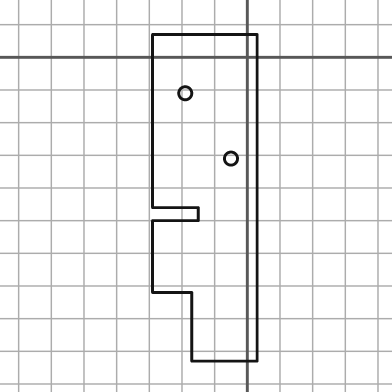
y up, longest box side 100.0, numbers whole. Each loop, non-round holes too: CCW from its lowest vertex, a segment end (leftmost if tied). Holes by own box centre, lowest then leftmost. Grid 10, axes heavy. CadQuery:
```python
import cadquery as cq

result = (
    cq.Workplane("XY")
    .moveTo(-17.0, -93.0)
    .lineTo(3.0, -93.0)
    .lineTo(3.0, 7.0)
    .lineTo(-29.0, 7.0)
    .lineTo(-29.0, -46.0)
    .lineTo(-15.0, -46.0)
    .lineTo(-15.0, -50.0)
    .lineTo(-29.0, -50.0)
    .lineTo(-29.0, -72.0)
    .lineTo(-17.0, -72.0)
    .close()
    .moveTo(-5.0, -31.0)
    .circle(2.0)
    .moveTo(-19.0, -11.0)
    .circle(2.0)
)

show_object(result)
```